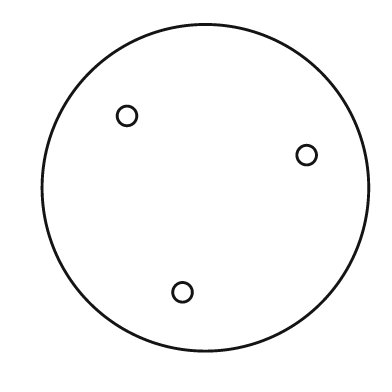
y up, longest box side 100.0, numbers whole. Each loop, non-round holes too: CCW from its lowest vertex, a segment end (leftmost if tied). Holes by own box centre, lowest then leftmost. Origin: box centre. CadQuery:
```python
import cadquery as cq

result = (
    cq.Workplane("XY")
    .moveTo(0.0, 0.0)
    .circle(50.0)
    .moveTo(-7.0, -32.0)
    .circle(3.0)
    .moveTo(31.0, 10.0)
    .circle(3.0)
    .moveTo(-24.0, 22.0)
    .circle(3.0)
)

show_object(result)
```